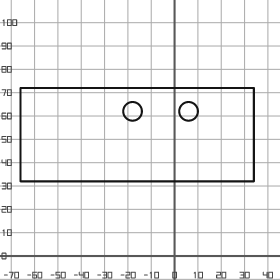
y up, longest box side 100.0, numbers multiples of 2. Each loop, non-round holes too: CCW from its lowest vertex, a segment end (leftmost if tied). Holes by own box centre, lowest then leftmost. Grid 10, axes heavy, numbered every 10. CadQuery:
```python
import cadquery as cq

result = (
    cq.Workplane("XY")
    .moveTo(-66.0, 32.0)
    .lineTo(34.0, 32.0)
    .lineTo(34.0, 72.0)
    .lineTo(-66.0, 72.0)
    .close()
    .moveTo(-18.0, 62.0)
    .circle(4.0)
    .moveTo(6.0, 62.0)
    .circle(4.0)
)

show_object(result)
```